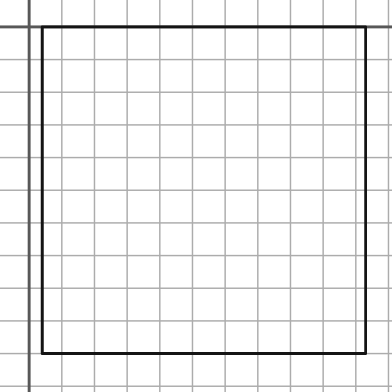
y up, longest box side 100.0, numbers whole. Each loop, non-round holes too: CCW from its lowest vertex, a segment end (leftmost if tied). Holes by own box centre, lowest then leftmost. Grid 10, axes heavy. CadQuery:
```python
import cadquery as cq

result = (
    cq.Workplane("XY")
    .moveTo(4.0, -100.0)
    .lineTo(103.0, -100.0)
    .lineTo(103.0, 0.0)
    .lineTo(4.0, 0.0)
    .close()
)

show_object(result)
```